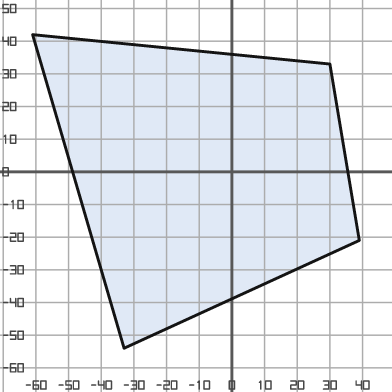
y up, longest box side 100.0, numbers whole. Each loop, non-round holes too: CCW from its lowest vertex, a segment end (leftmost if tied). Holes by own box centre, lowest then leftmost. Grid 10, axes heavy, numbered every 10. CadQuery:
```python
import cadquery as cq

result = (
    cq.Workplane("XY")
    .moveTo(-33.0, -54.0)
    .lineTo(39.0, -21.0)
    .lineTo(30.0, 33.0)
    .lineTo(-61.0, 42.0)
    .close()
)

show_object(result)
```